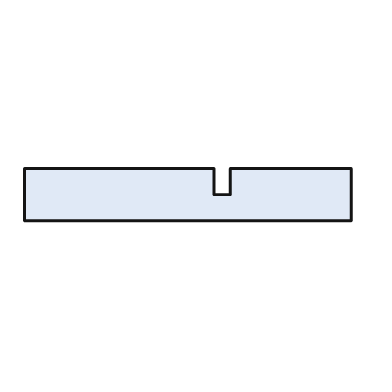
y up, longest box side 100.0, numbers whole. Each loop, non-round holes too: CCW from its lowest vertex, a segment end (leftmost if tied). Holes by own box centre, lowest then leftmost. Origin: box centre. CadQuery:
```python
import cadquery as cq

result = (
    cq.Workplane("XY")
    .moveTo(-50.0, -8.0)
    .lineTo(50.0, -8.0)
    .lineTo(50.0, 8.0)
    .lineTo(13.0, 8.0)
    .lineTo(13.0, 0.0)
    .lineTo(8.0, 0.0)
    .lineTo(8.0, 8.0)
    .lineTo(-50.0, 8.0)
    .close()
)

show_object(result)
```